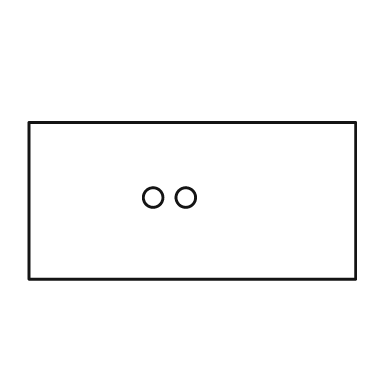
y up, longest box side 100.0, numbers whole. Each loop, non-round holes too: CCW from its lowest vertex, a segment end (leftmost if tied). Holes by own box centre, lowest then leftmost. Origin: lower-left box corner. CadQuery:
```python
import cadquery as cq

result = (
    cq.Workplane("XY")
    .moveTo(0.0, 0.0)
    .lineTo(100.0, 0.0)
    .lineTo(100.0, 48.0)
    .lineTo(0.0, 48.0)
    .close()
    .moveTo(38.0, 25.0)
    .circle(3.0)
    .moveTo(48.0, 25.0)
    .circle(3.0)
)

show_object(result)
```